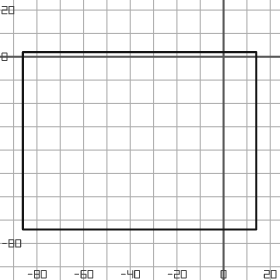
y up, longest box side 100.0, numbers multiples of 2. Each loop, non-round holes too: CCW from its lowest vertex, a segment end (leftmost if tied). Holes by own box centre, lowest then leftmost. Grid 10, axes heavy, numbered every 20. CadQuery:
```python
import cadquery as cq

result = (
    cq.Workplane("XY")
    .moveTo(-86.0, -74.0)
    .lineTo(14.0, -74.0)
    .lineTo(14.0, 2.0)
    .lineTo(-86.0, 2.0)
    .close()
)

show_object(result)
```